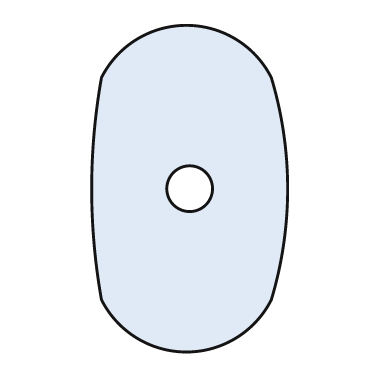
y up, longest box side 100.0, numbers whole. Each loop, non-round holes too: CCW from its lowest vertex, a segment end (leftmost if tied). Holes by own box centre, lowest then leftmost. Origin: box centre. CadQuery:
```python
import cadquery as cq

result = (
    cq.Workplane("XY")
    .moveTo(-27.0, -34.0)
    .threePointArc((-1.0, -50.0), (25.0, -34.0))
    .threePointArc((30.0, 0.0), (25.0, 34.0))
    .threePointArc((-1.0, 50.0), (-27.0, 34.0))
    .threePointArc((-30.0, 0.0), (-27.0, -34.0))
    .close()
    .moveTo(0.0, 0.0)
    .circle(7.0)
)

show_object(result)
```